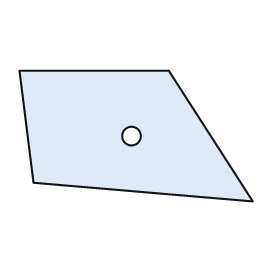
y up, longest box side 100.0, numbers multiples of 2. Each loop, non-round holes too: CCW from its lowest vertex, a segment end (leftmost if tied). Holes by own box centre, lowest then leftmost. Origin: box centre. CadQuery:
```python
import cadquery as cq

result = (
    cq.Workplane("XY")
    .moveTo(50.0, -28.0)
    .lineTo(14.0, 28.0)
    .lineTo(-50.0, 28.0)
    .lineTo(-44.0, -20.0)
    .close()
    .moveTo(-2.0, 0.0)
    .circle(4.0)
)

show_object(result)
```